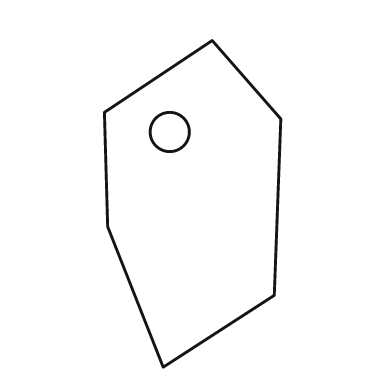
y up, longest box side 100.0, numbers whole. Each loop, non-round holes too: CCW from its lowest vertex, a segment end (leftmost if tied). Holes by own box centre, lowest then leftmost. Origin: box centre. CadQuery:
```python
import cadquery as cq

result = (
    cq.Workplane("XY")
    .moveTo(-9.0, -50.0)
    .lineTo(25.0, -28.0)
    .lineTo(27.0, 26.0)
    .lineTo(6.0, 50.0)
    .lineTo(-27.0, 28.0)
    .lineTo(-26.0, -7.0)
    .close()
    .moveTo(-7.0, 22.0)
    .circle(6.0)
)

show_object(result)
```